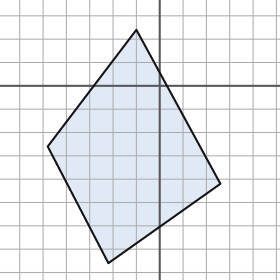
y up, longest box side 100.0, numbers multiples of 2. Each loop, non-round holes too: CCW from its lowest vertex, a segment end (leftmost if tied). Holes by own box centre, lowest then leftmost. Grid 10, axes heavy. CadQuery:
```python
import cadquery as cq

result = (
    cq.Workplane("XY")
    .moveTo(-22.0, -76.0)
    .lineTo(26.0, -42.0)
    .lineTo(-10.0, 24.0)
    .lineTo(-48.0, -26.0)
    .close()
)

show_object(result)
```